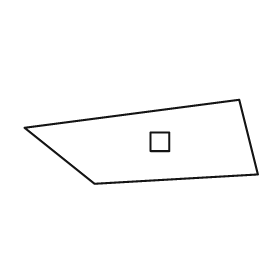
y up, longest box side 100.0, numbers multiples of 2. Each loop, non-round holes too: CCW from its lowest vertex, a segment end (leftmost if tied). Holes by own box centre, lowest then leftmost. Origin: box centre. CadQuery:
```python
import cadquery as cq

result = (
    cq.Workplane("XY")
    .moveTo(-20.0, -18.0)
    .lineTo(50.0, -14.0)
    .lineTo(42.0, 18.0)
    .lineTo(-50.0, 6.0)
    .close()
    .moveTo(4.0, -4.0)
    .lineTo(12.0, -4.0)
    .lineTo(12.0, 4.0)
    .lineTo(4.0, 4.0)
    .close()
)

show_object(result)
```